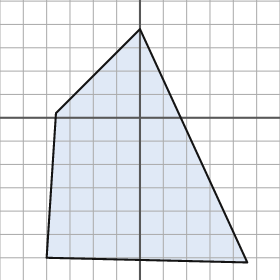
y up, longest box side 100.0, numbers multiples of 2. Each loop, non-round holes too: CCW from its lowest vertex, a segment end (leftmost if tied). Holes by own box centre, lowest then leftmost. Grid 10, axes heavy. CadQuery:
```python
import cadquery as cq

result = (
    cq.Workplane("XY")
    .moveTo(46.0, -62.0)
    .lineTo(0.0, 38.0)
    .lineTo(-36.0, 2.0)
    .lineTo(-40.0, -60.0)
    .close()
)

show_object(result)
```